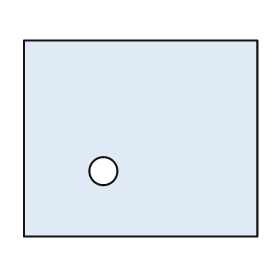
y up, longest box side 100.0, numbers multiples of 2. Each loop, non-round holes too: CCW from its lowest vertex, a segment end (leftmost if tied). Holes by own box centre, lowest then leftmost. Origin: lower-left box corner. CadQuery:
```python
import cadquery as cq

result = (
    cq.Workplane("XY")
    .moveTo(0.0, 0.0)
    .lineTo(100.0, 0.0)
    .lineTo(100.0, 84.0)
    .lineTo(0.0, 84.0)
    .close()
    .moveTo(34.0, 28.0)
    .circle(6.0)
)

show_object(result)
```